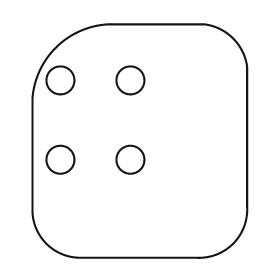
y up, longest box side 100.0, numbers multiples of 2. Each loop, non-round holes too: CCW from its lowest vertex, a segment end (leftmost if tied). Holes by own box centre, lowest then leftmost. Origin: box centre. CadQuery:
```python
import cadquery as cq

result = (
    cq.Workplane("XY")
    .moveTo(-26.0, -50.0)
    .lineTo(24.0, -50.0)
    .threePointArc((40.0, -44.0), (46.0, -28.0))
    .lineTo(46.0, 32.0)
    .threePointArc((40.0, 44.0), (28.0, 50.0))
    .lineTo(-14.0, 50.0)
    .threePointArc((-36.0, 40.0), (-46.0, 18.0))
    .lineTo(-46.0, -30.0)
    .threePointArc((-40.0, -44.0), (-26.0, -50.0))
    .close()
    .moveTo(-34.0, -8.0)
    .circle(6.0)
    .moveTo(-4.0, -8.0)
    .circle(6.0)
    .moveTo(-34.0, 26.0)
    .circle(6.0)
    .moveTo(-4.0, 26.0)
    .circle(6.0)
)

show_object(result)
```